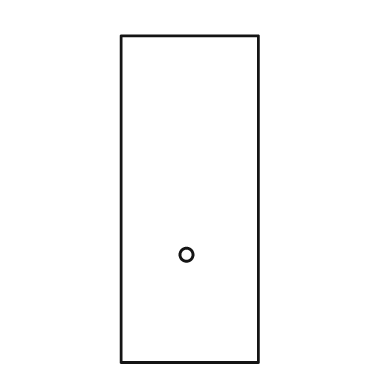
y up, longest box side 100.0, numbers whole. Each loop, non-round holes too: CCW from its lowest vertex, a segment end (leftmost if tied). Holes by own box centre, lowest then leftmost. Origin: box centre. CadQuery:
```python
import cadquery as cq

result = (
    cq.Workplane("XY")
    .moveTo(-21.0, -50.0)
    .lineTo(21.0, -50.0)
    .lineTo(21.0, 50.0)
    .lineTo(-21.0, 50.0)
    .close()
    .moveTo(-1.0, -17.0)
    .circle(2.0)
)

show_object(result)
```